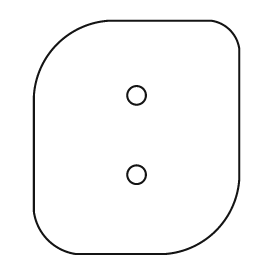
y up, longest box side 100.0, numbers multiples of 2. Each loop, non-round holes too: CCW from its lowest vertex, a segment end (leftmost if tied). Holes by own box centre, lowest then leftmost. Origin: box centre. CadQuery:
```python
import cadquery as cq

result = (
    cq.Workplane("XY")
    .moveTo(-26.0, -50.0)
    .lineTo(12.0, -50.0)
    .threePointArc((34.0, -40.0), (44.0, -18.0))
    .lineTo(44.0, 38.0)
    .threePointArc((40.0, 46.0), (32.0, 50.0))
    .lineTo(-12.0, 50.0)
    .threePointArc((-34.0, 40.0), (-44.0, 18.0))
    .lineTo(-44.0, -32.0)
    .threePointArc((-38.0, -44.0), (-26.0, -50.0))
    .close()
    .moveTo(0.0, -16.0)
    .circle(4.0)
    .moveTo(0.0, 18.0)
    .circle(4.0)
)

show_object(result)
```